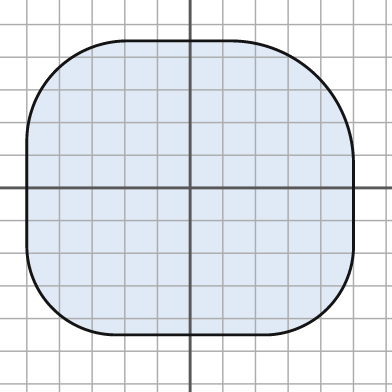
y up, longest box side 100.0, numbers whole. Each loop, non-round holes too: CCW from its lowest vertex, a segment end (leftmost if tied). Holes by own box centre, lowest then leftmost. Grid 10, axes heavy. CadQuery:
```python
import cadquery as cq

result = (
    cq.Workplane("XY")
    .moveTo(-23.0, -45.0)
    .lineTo(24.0, -45.0)
    .threePointArc((42.0, -37.0), (50.0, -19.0))
    .lineTo(50.0, 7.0)
    .threePointArc((39.0, 34.0), (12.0, 45.0))
    .lineTo(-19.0, 45.0)
    .threePointArc((-41.0, 36.0), (-50.0, 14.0))
    .lineTo(-50.0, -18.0)
    .threePointArc((-42.0, -37.0), (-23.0, -45.0))
    .close()
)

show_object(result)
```